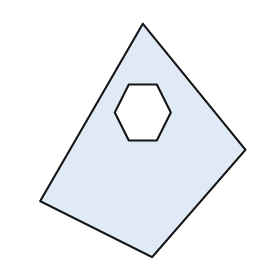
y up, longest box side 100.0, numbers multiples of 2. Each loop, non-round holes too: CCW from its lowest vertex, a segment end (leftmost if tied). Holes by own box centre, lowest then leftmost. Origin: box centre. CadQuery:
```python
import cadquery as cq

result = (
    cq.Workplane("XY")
    .moveTo(4.0, -50.0)
    .lineTo(44.0, -4.0)
    .lineTo(0.0, 50.0)
    .lineTo(-44.0, -26.0)
    .close()
    .moveTo(-6.0, 0.0)
    .lineTo(6.0, 0.0)
    .lineTo(12.0, 12.0)
    .lineTo(6.0, 24.0)
    .lineTo(-6.0, 24.0)
    .lineTo(-12.0, 12.0)
    .close()
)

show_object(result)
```